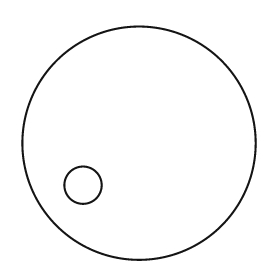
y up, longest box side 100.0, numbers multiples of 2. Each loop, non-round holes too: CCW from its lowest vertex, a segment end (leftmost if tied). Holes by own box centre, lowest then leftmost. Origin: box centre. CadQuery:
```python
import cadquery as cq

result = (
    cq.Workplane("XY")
    .moveTo(0.0, 0.0)
    .circle(50.0)
    .moveTo(-24.0, -18.0)
    .circle(8.0)
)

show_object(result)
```